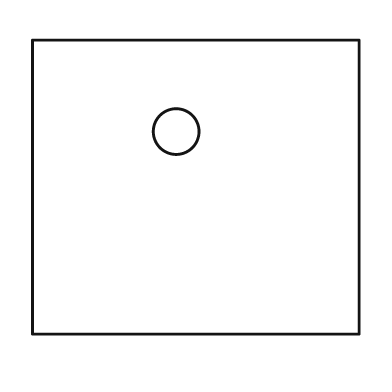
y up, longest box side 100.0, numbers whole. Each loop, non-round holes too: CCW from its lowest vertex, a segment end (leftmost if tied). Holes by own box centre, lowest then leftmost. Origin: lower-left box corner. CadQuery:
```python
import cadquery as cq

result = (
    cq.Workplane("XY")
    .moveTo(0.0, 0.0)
    .lineTo(100.0, 0.0)
    .lineTo(100.0, 90.0)
    .lineTo(0.0, 90.0)
    .close()
    .moveTo(44.0, 62.0)
    .circle(7.0)
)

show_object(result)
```